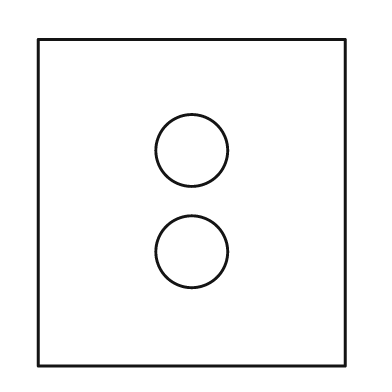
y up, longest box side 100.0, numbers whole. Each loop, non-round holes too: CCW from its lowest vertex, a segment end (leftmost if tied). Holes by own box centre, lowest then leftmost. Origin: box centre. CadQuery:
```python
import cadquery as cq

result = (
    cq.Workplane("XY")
    .moveTo(-47.0, -50.0)
    .lineTo(47.0, -50.0)
    .lineTo(47.0, 50.0)
    .lineTo(-47.0, 50.0)
    .close()
    .moveTo(0.0, -15.0)
    .circle(11.0)
    .moveTo(0.0, 16.0)
    .circle(11.0)
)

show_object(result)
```